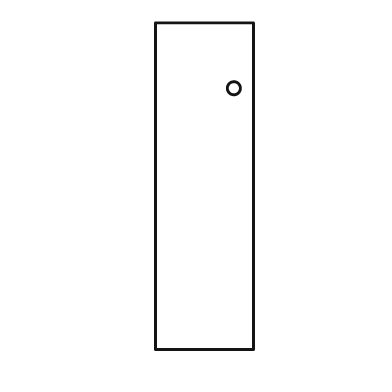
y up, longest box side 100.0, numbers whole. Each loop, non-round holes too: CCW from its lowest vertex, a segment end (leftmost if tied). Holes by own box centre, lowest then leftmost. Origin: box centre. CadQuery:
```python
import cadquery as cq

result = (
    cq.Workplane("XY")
    .moveTo(-15.0, -50.0)
    .lineTo(15.0, -50.0)
    .lineTo(15.0, 50.0)
    .lineTo(-15.0, 50.0)
    .close()
    .moveTo(9.0, 30.0)
    .circle(2.0)
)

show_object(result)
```